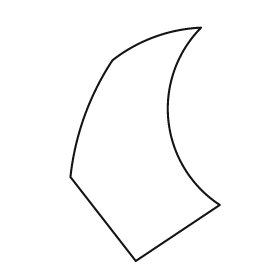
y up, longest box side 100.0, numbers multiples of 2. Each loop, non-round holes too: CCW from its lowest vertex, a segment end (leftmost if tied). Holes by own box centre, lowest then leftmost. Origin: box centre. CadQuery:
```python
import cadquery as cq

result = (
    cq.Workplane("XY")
    .moveTo(-4.0, -50.0)
    .lineTo(32.0, -26.0)
    .threePointArc((10.0, 10.0), (24.0, 50.0))
    .threePointArc((4.0, 46.0), (-14.0, 36.0))
    .threePointArc((-26.0, 12.0), (-32.0, -14.0))
    .close()
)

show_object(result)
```